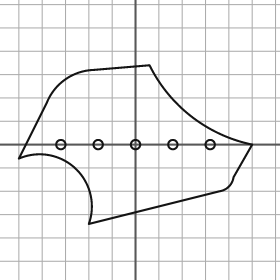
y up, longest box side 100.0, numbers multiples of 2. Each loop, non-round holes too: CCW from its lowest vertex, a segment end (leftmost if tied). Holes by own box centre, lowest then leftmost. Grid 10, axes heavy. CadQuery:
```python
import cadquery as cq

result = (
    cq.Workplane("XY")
    .moveTo(-20.0, -34.0)
    .lineTo(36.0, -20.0)
    .threePointArc((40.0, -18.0), (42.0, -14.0))
    .lineTo(50.0, 0.0)
    .threePointArc((24.0, 12.0), (6.0, 34.0))
    .lineTo(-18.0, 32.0)
    .threePointArc((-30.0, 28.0), (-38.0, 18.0))
    .lineTo(-50.0, -6.0)
    .threePointArc((-26.0, -10.0), (-20.0, -34.0))
    .close()
    .moveTo(-32.0, 0.0)
    .circle(2.0)
    .moveTo(-16.0, 0.0)
    .circle(2.0)
    .moveTo(0.0, 0.0)
    .circle(2.0)
    .moveTo(16.0, 0.0)
    .circle(2.0)
    .moveTo(32.0, 0.0)
    .circle(2.0)
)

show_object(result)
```